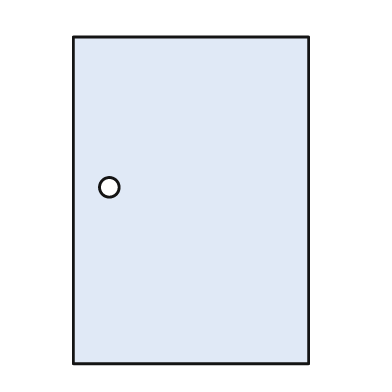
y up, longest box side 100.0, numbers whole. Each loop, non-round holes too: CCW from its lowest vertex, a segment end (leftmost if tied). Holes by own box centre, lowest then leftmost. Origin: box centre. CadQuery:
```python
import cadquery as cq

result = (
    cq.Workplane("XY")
    .moveTo(-36.0, -50.0)
    .lineTo(36.0, -50.0)
    .lineTo(36.0, 50.0)
    .lineTo(-36.0, 50.0)
    .close()
    .moveTo(-25.0, 4.0)
    .circle(3.0)
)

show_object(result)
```